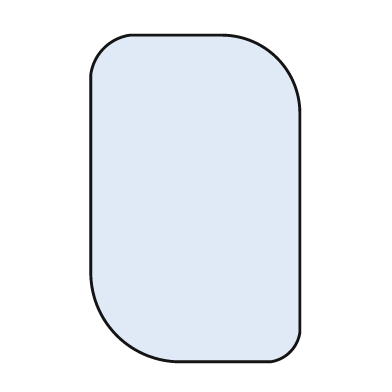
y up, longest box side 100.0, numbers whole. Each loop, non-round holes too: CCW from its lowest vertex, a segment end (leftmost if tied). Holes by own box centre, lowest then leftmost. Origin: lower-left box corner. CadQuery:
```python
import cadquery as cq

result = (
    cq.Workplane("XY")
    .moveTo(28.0, 0.0)
    .lineTo(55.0, 0.0)
    .threePointArc((61.0, 3.0), (64.0, 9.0))
    .lineTo(64.0, 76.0)
    .threePointArc((57.0, 93.0), (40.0, 100.0))
    .lineTo(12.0, 100.0)
    .threePointArc((4.0, 96.0), (0.0, 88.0))
    .lineTo(0.0, 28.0)
    .threePointArc((8.0, 8.0), (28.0, 0.0))
    .close()
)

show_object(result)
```